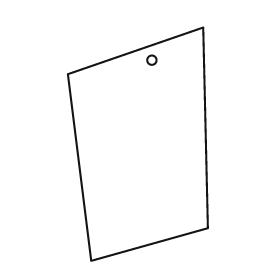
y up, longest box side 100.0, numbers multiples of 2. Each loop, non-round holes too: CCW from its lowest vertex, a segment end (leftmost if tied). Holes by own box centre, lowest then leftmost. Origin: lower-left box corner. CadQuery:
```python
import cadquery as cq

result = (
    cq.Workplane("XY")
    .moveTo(10.0, 0.0)
    .lineTo(60.0, 14.0)
    .lineTo(58.0, 100.0)
    .lineTo(0.0, 80.0)
    .close()
    .moveTo(36.0, 86.0)
    .circle(2.0)
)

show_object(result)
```